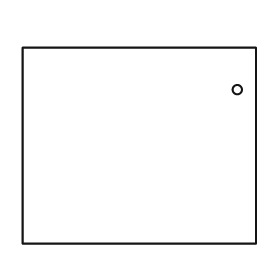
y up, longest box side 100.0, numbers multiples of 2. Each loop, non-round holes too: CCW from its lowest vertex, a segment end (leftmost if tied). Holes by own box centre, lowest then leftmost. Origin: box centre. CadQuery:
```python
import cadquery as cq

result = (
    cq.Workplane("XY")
    .moveTo(-50.0, -42.0)
    .lineTo(50.0, -42.0)
    .lineTo(50.0, 42.0)
    .lineTo(-50.0, 42.0)
    .close()
    .moveTo(42.0, 24.0)
    .circle(2.0)
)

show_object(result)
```